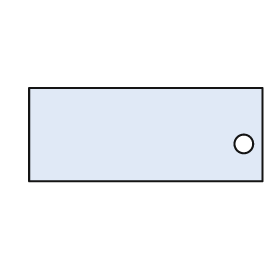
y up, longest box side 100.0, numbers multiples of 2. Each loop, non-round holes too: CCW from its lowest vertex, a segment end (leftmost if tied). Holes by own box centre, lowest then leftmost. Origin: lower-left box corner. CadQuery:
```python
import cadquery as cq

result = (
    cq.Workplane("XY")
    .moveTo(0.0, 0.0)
    .lineTo(100.0, 0.0)
    .lineTo(100.0, 40.0)
    .lineTo(0.0, 40.0)
    .close()
    .moveTo(92.0, 16.0)
    .circle(4.0)
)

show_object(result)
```